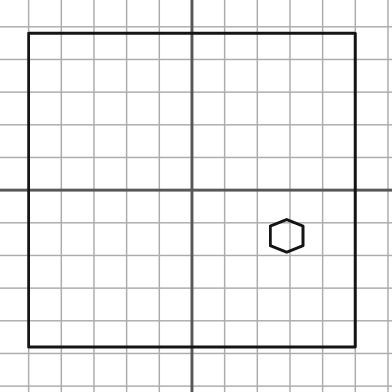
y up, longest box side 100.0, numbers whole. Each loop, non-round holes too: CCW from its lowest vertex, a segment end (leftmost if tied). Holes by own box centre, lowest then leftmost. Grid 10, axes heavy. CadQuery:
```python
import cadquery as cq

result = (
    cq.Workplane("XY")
    .moveTo(-50.0, -48.0)
    .lineTo(50.0, -48.0)
    .lineTo(50.0, 48.0)
    .lineTo(-50.0, 48.0)
    .close()
    .moveTo(29.0, -19.0)
    .lineTo(34.0, -17.0)
    .lineTo(34.0, -11.0)
    .lineTo(29.0, -9.0)
    .lineTo(24.0, -11.0)
    .lineTo(24.0, -17.0)
    .close()
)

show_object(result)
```